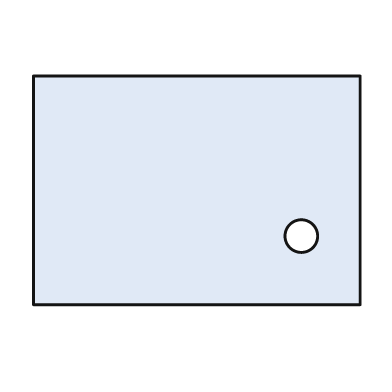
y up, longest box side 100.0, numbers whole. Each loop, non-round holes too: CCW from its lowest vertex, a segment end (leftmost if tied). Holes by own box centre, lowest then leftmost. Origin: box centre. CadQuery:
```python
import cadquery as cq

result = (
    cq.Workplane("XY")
    .moveTo(-50.0, -35.0)
    .lineTo(50.0, -35.0)
    .lineTo(50.0, 35.0)
    .lineTo(-50.0, 35.0)
    .close()
    .moveTo(32.0, -14.0)
    .circle(5.0)
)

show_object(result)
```